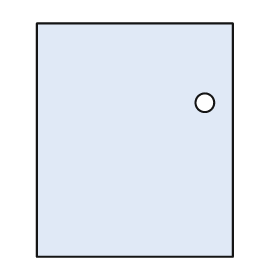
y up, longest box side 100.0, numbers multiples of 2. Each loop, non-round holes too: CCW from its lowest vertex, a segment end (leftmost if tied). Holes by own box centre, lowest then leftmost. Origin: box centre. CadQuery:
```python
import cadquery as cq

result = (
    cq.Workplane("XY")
    .moveTo(-42.0, -50.0)
    .lineTo(42.0, -50.0)
    .lineTo(42.0, 50.0)
    .lineTo(-42.0, 50.0)
    .close()
    .moveTo(30.0, 16.0)
    .circle(4.0)
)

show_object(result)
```